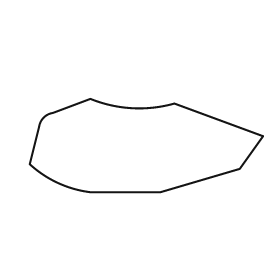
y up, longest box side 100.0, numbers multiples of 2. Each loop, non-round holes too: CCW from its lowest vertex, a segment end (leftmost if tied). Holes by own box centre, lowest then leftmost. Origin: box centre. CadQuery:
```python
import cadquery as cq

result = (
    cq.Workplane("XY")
    .moveTo(-24.0, -20.0)
    .lineTo(6.0, -20.0)
    .lineTo(40.0, -10.0)
    .lineTo(50.0, 4.0)
    .lineTo(12.0, 18.0)
    .threePointArc((-6.0, 16.0), (-24.0, 20.0))
    .lineTo(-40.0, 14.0)
    .threePointArc((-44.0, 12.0), (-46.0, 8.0))
    .lineTo(-50.0, -8.0)
    .threePointArc((-38.0, -16.0), (-24.0, -20.0))
    .close()
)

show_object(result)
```